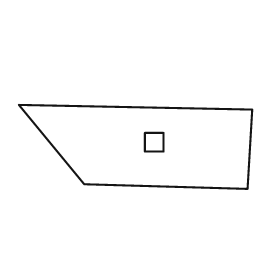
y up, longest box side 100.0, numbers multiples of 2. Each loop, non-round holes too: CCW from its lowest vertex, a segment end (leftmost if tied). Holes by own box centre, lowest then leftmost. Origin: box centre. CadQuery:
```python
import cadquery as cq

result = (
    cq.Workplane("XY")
    .moveTo(48.0, -18.0)
    .lineTo(50.0, 16.0)
    .lineTo(-50.0, 18.0)
    .lineTo(-22.0, -16.0)
    .close()
    .moveTo(4.0, -2.0)
    .lineTo(12.0, -2.0)
    .lineTo(12.0, 6.0)
    .lineTo(4.0, 6.0)
    .close()
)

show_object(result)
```